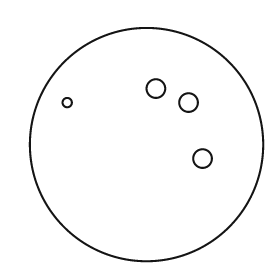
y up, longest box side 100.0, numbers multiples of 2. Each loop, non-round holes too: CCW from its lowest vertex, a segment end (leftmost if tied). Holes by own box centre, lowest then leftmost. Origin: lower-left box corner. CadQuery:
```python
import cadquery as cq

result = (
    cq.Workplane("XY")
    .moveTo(50.0, 50.0)
    .circle(50.0)
    .moveTo(74.0, 44.0)
    .circle(4.0)
    .moveTo(16.0, 68.0)
    .circle(2.0)
    .moveTo(68.0, 68.0)
    .circle(4.0)
    .moveTo(54.0, 74.0)
    .circle(4.0)
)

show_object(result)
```